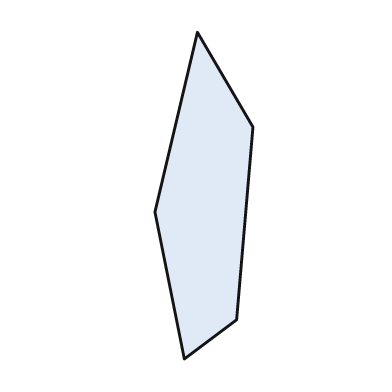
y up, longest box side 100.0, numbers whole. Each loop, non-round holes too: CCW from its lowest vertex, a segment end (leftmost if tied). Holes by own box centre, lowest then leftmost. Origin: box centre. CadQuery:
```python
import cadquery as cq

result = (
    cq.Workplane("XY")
    .moveTo(-6.0, -50.0)
    .lineTo(10.0, -38.0)
    .lineTo(15.0, 21.0)
    .lineTo(-2.0, 50.0)
    .lineTo(-15.0, -5.0)
    .close()
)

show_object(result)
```